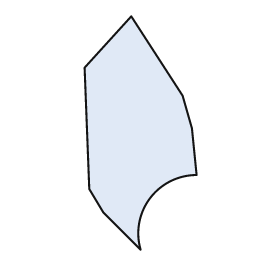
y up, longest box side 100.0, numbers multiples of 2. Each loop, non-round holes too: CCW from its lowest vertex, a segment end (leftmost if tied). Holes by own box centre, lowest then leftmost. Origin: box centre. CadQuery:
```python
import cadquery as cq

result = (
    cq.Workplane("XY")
    .moveTo(0.0, -50.0)
    .threePointArc((4.0, -28.0), (24.0, -18.0))
    .lineTo(22.0, 2.0)
    .lineTo(18.0, 16.0)
    .lineTo(-4.0, 50.0)
    .lineTo(-24.0, 28.0)
    .lineTo(-22.0, -24.0)
    .lineTo(-16.0, -34.0)
    .close()
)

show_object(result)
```